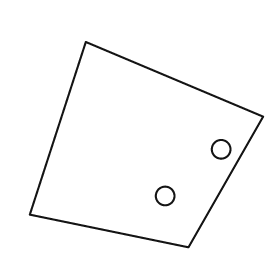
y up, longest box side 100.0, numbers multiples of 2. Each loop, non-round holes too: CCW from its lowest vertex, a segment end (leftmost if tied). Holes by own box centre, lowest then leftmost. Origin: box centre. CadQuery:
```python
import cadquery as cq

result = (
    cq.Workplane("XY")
    .moveTo(18.0, -44.0)
    .lineTo(50.0, 12.0)
    .lineTo(-26.0, 44.0)
    .lineTo(-50.0, -30.0)
    .close()
    .moveTo(8.0, -22.0)
    .circle(4.0)
    .moveTo(32.0, -2.0)
    .circle(4.0)
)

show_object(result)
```